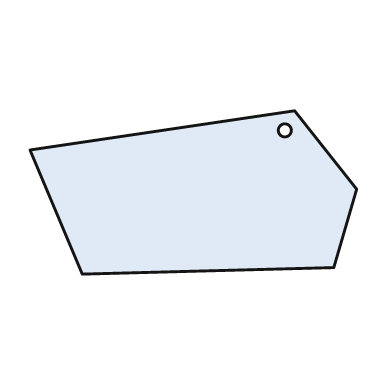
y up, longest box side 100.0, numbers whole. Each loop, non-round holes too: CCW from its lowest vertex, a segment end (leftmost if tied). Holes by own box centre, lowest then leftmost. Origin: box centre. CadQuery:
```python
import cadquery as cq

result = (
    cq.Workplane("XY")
    .moveTo(-34.0, -25.0)
    .lineTo(43.0, -23.0)
    .lineTo(50.0, 1.0)
    .lineTo(31.0, 25.0)
    .lineTo(-50.0, 13.0)
    .close()
    .moveTo(28.0, 19.0)
    .circle(2.0)
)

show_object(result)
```